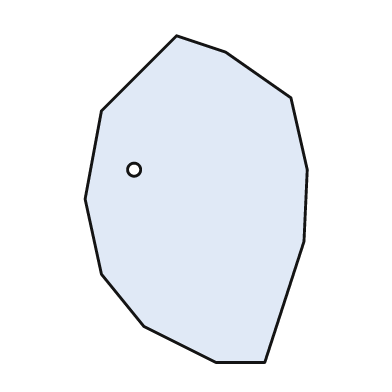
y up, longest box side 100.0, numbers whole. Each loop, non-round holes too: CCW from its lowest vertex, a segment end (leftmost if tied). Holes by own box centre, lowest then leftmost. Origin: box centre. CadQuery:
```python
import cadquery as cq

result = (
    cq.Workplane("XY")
    .moveTo(6.0, -50.0)
    .lineTo(21.0, -50.0)
    .lineTo(33.0, -13.0)
    .lineTo(34.0, 9.0)
    .lineTo(29.0, 31.0)
    .lineTo(9.0, 45.0)
    .lineTo(-6.0, 50.0)
    .lineTo(-29.0, 27.0)
    .lineTo(-34.0, 0.0)
    .lineTo(-29.0, -23.0)
    .lineTo(-16.0, -39.0)
    .close()
    .moveTo(-19.0, 9.0)
    .circle(2.0)
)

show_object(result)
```